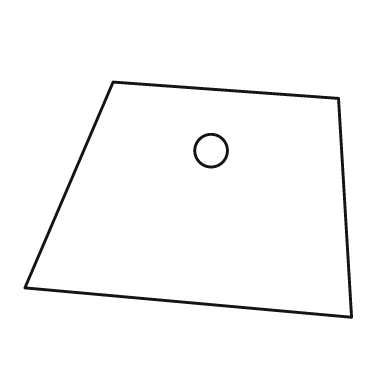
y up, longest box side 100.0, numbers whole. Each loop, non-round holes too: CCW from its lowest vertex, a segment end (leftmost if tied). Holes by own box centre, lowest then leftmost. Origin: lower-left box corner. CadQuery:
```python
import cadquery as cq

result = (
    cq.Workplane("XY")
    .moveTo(100.0, 0.0)
    .lineTo(96.0, 67.0)
    .lineTo(27.0, 72.0)
    .lineTo(0.0, 9.0)
    .close()
    .moveTo(57.0, 51.0)
    .circle(5.0)
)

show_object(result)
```